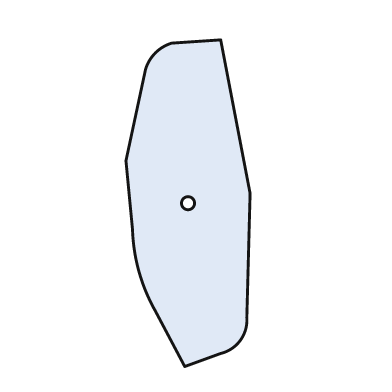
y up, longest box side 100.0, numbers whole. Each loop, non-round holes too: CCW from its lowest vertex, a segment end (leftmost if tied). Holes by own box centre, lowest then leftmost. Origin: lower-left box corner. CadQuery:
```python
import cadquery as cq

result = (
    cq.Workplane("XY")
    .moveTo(18.0, 0.0)
    .lineTo(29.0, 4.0)
    .threePointArc((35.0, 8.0), (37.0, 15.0))
    .lineTo(38.0, 53.0)
    .lineTo(29.0, 100.0)
    .lineTo(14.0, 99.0)
    .threePointArc((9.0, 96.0), (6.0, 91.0))
    .lineTo(0.0, 63.0)
    .lineTo(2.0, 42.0)
    .threePointArc((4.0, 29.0), (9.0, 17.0))
    .close()
    .moveTo(19.0, 50.0)
    .circle(2.0)
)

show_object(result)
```